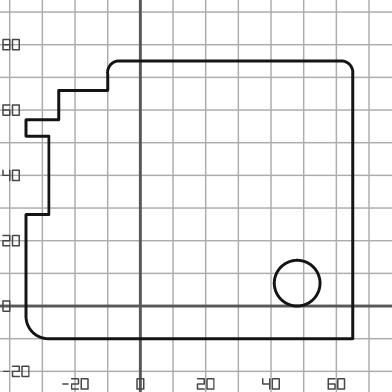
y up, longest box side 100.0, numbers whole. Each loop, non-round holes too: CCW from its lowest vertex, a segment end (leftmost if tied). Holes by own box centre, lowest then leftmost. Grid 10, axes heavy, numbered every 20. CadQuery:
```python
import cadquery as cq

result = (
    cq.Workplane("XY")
    .moveTo(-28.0, -10.0)
    .lineTo(65.0, -10.0)
    .lineTo(65.0, 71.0)
    .threePointArc((64.0, 74.0), (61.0, 75.0))
    .lineTo(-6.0, 75.0)
    .threePointArc((-9.0, 74.0), (-10.0, 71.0))
    .lineTo(-10.0, 66.0)
    .lineTo(-25.0, 66.0)
    .lineTo(-25.0, 57.0)
    .lineTo(-35.0, 57.0)
    .lineTo(-35.0, 52.0)
    .lineTo(-28.0, 52.0)
    .lineTo(-28.0, 28.0)
    .lineTo(-35.0, 28.0)
    .lineTo(-35.0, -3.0)
    .threePointArc((-33.0, -8.0), (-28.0, -10.0))
    .close()
    .moveTo(48.0, 7.0)
    .circle(7.0)
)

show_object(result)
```